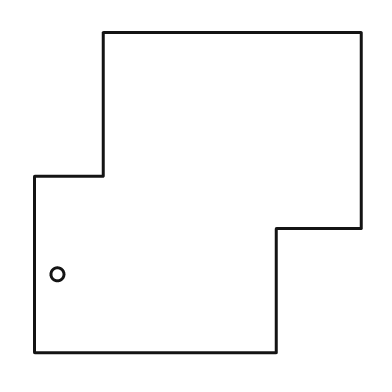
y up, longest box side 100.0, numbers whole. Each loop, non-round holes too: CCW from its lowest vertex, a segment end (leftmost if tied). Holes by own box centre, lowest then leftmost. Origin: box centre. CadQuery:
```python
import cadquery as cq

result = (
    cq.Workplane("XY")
    .moveTo(-50.0, -49.0)
    .lineTo(24.0, -49.0)
    .lineTo(24.0, -11.0)
    .lineTo(50.0, -11.0)
    .lineTo(50.0, 49.0)
    .lineTo(-29.0, 49.0)
    .lineTo(-29.0, 5.0)
    .lineTo(-50.0, 5.0)
    .close()
    .moveTo(-43.0, -25.0)
    .circle(2.0)
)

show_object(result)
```